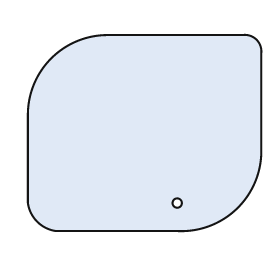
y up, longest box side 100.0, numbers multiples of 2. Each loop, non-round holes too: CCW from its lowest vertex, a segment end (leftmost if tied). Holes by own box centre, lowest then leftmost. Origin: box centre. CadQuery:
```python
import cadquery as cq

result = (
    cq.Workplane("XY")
    .moveTo(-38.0, -42.0)
    .lineTo(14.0, -42.0)
    .threePointArc((40.0, -32.0), (50.0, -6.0))
    .lineTo(50.0, 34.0)
    .threePointArc((48.0, 40.0), (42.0, 42.0))
    .lineTo(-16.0, 42.0)
    .threePointArc((-40.0, 32.0), (-50.0, 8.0))
    .lineTo(-50.0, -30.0)
    .threePointArc((-46.0, -38.0), (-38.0, -42.0))
    .close()
    .moveTo(14.0, -30.0)
    .circle(2.0)
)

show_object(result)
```